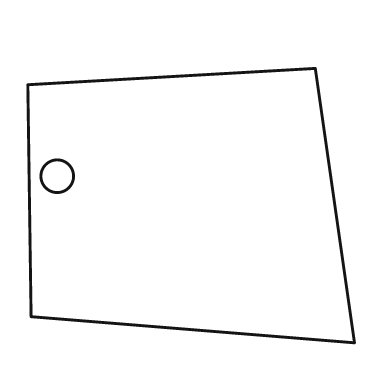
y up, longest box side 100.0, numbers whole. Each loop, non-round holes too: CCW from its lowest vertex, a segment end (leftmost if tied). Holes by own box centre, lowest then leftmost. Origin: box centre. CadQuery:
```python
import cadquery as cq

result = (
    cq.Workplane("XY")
    .moveTo(50.0, -42.0)
    .lineTo(38.0, 42.0)
    .lineTo(-50.0, 37.0)
    .lineTo(-49.0, -34.0)
    .close()
    .moveTo(-41.0, 9.0)
    .circle(5.0)
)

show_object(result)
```